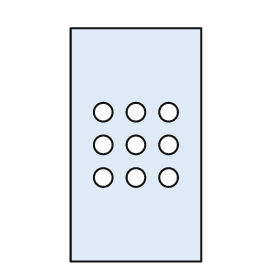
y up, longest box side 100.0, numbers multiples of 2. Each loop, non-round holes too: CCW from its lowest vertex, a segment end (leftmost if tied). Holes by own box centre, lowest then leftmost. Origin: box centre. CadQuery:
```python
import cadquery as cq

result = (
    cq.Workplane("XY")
    .moveTo(-28.0, -50.0)
    .lineTo(28.0, -50.0)
    .lineTo(28.0, 50.0)
    .lineTo(-28.0, 50.0)
    .close()
    .moveTo(-14.0, -14.0)
    .circle(4.0)
    .moveTo(0.0, -14.0)
    .circle(4.0)
    .moveTo(14.0, -14.0)
    .circle(4.0)
    .moveTo(-14.0, 0.0)
    .circle(4.0)
    .moveTo(0.0, 0.0)
    .circle(4.0)
    .moveTo(14.0, 0.0)
    .circle(4.0)
    .moveTo(-14.0, 14.0)
    .circle(4.0)
    .moveTo(0.0, 14.0)
    .circle(4.0)
    .moveTo(14.0, 14.0)
    .circle(4.0)
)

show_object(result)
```